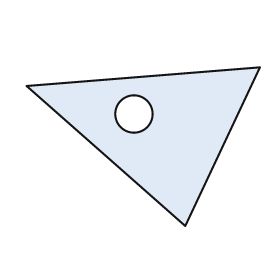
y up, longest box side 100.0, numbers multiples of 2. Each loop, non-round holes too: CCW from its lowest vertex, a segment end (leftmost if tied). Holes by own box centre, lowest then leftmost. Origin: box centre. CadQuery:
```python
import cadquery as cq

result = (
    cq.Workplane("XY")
    .moveTo(18.0, -34.0)
    .lineTo(50.0, 34.0)
    .lineTo(-50.0, 26.0)
    .close()
    .moveTo(-4.0, 14.0)
    .circle(8.0)
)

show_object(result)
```